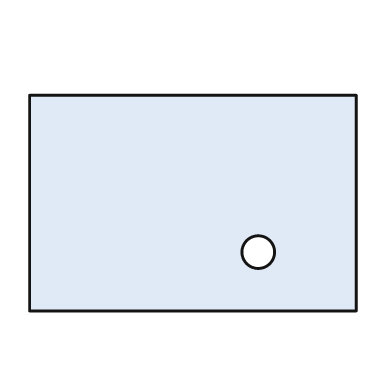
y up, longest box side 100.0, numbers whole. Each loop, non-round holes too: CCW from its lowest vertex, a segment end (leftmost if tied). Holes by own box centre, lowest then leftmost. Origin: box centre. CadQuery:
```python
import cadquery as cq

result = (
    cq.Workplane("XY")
    .moveTo(-50.0, -33.0)
    .lineTo(50.0, -33.0)
    .lineTo(50.0, 33.0)
    .lineTo(-50.0, 33.0)
    .close()
    .moveTo(20.0, -15.0)
    .circle(5.0)
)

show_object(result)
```